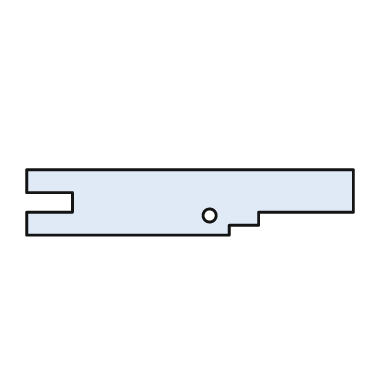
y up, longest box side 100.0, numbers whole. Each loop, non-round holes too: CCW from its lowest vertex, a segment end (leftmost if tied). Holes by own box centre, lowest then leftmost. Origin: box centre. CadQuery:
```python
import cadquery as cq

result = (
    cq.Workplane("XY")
    .moveTo(-50.0, -10.0)
    .lineTo(12.0, -10.0)
    .lineTo(12.0, -7.0)
    .lineTo(21.0, -7.0)
    .lineTo(21.0, -3.0)
    .lineTo(50.0, -3.0)
    .lineTo(50.0, 10.0)
    .lineTo(-50.0, 10.0)
    .lineTo(-50.0, 3.0)
    .lineTo(-36.0, 3.0)
    .lineTo(-36.0, -3.0)
    .lineTo(-50.0, -3.0)
    .close()
    .moveTo(6.0, -4.0)
    .circle(2.0)
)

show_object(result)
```